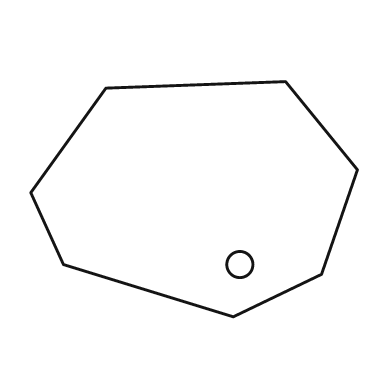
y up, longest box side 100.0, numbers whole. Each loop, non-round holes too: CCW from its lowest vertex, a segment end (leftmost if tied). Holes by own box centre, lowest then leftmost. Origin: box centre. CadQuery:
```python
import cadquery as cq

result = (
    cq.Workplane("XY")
    .moveTo(12.0, -36.0)
    .lineTo(39.0, -23.0)
    .lineTo(50.0, 9.0)
    .lineTo(28.0, 36.0)
    .lineTo(-27.0, 34.0)
    .lineTo(-50.0, 2.0)
    .lineTo(-40.0, -20.0)
    .close()
    .moveTo(14.0, -20.0)
    .circle(4.0)
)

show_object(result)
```